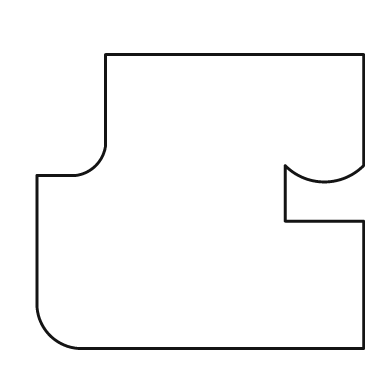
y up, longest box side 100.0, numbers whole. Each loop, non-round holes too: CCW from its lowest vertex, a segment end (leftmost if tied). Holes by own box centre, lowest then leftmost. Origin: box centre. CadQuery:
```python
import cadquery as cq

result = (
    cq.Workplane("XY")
    .moveTo(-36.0, -45.0)
    .lineTo(50.0, -45.0)
    .lineTo(50.0, -6.0)
    .lineTo(26.0, -6.0)
    .lineTo(26.0, 11.0)
    .threePointArc((38.0, 6.0), (50.0, 11.0))
    .lineTo(50.0, 45.0)
    .lineTo(-29.0, 45.0)
    .lineTo(-29.0, 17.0)
    .threePointArc((-32.0, 11.0), (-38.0, 8.0))
    .lineTo(-50.0, 8.0)
    .lineTo(-50.0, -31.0)
    .threePointArc((-46.0, -41.0), (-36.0, -45.0))
    .close()
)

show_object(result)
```